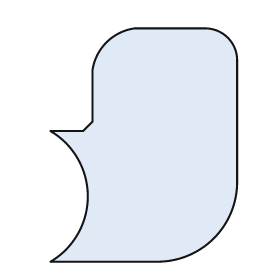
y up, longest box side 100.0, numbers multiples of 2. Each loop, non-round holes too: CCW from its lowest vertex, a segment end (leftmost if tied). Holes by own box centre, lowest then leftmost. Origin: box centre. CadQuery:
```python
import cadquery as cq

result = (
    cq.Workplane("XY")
    .moveTo(-40.0, -50.0)
    .lineTo(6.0, -50.0)
    .threePointArc((30.0, -40.0), (40.0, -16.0))
    .lineTo(40.0, 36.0)
    .threePointArc((36.0, 46.0), (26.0, 50.0))
    .lineTo(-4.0, 50.0)
    .threePointArc((-16.0, 44.0), (-22.0, 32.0))
    .lineTo(-22.0, 10.0)
    .lineTo(-26.0, 6.0)
    .lineTo(-40.0, 6.0)
    .threePointArc((-24.0, -22.0), (-40.0, -50.0))
    .close()
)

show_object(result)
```